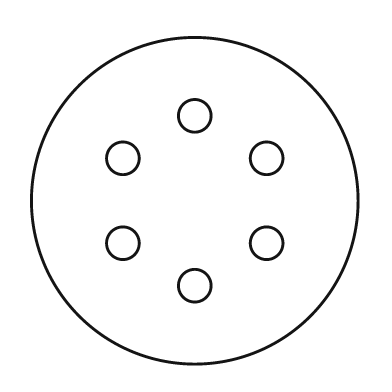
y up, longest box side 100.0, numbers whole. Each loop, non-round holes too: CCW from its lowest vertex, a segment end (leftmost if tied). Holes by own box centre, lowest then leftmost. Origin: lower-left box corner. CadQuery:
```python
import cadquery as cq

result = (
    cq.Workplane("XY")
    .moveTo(50.0, 50.0)
    .circle(50.0)
    .moveTo(50.0, 24.0)
    .circle(5.0)
    .moveTo(28.0, 37.0)
    .circle(5.0)
    .moveTo(72.0, 37.0)
    .circle(5.0)
    .moveTo(28.0, 63.0)
    .circle(5.0)
    .moveTo(72.0, 63.0)
    .circle(5.0)
    .moveTo(50.0, 76.0)
    .circle(5.0)
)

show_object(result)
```